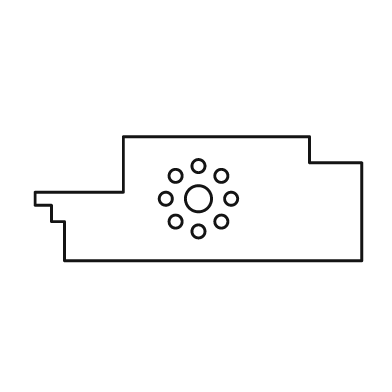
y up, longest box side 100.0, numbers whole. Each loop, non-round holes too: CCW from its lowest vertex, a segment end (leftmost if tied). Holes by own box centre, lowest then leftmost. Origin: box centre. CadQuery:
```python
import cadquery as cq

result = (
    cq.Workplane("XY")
    .moveTo(-41.0, -19.0)
    .lineTo(50.0, -19.0)
    .lineTo(50.0, 11.0)
    .lineTo(34.0, 11.0)
    .lineTo(34.0, 19.0)
    .lineTo(-23.0, 19.0)
    .lineTo(-23.0, 2.0)
    .lineTo(-50.0, 2.0)
    .lineTo(-50.0, -2.0)
    .lineTo(-45.0, -2.0)
    .lineTo(-45.0, -7.0)
    .lineTo(-41.0, -7.0)
    .close()
    .moveTo(0.0, -10.0)
    .circle(2.0)
    .moveTo(-7.0, -7.0)
    .circle(2.0)
    .moveTo(7.0, -7.0)
    .circle(2.0)
    .moveTo(-10.0, 0.0)
    .circle(2.0)
    .moveTo(0.0, 0.0)
    .circle(4.0)
    .moveTo(10.0, 0.0)
    .circle(2.0)
    .moveTo(-7.0, 7.0)
    .circle(2.0)
    .moveTo(7.0, 7.0)
    .circle(2.0)
    .moveTo(0.0, 10.0)
    .circle(2.0)
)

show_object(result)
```